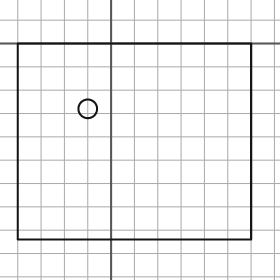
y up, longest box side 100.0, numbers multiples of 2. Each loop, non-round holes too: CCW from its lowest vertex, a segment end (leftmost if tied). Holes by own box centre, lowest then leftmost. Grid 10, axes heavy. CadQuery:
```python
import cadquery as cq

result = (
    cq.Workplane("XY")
    .moveTo(-40.0, -84.0)
    .lineTo(60.0, -84.0)
    .lineTo(60.0, 0.0)
    .lineTo(-40.0, 0.0)
    .close()
    .moveTo(-10.0, -28.0)
    .circle(4.0)
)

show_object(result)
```